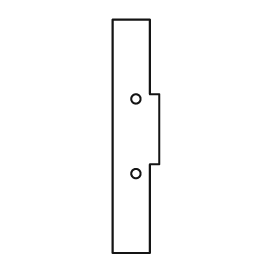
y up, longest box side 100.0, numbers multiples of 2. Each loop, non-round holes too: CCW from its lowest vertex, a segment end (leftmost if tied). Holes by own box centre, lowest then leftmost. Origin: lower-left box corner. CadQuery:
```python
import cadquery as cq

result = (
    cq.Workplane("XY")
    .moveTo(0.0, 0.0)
    .lineTo(16.0, 0.0)
    .lineTo(16.0, 38.0)
    .lineTo(20.0, 38.0)
    .lineTo(20.0, 68.0)
    .lineTo(16.0, 68.0)
    .lineTo(16.0, 100.0)
    .lineTo(0.0, 100.0)
    .close()
    .moveTo(10.0, 34.0)
    .circle(2.0)
    .moveTo(10.0, 66.0)
    .circle(2.0)
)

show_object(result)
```